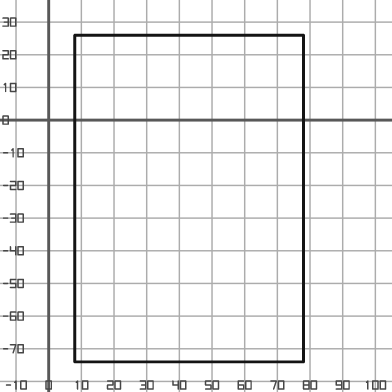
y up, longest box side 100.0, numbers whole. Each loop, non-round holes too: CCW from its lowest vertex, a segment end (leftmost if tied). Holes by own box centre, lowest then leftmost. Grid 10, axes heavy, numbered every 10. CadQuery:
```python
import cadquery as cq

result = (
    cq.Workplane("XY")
    .moveTo(8.0, -74.0)
    .lineTo(78.0, -74.0)
    .lineTo(78.0, 26.0)
    .lineTo(8.0, 26.0)
    .close()
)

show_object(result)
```